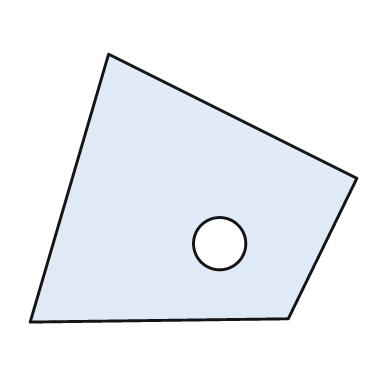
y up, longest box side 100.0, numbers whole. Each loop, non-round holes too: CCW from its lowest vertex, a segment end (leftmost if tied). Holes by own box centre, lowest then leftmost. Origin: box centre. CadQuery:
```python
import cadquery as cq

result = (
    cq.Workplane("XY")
    .moveTo(-50.0, -41.0)
    .lineTo(29.0, -40.0)
    .lineTo(50.0, 3.0)
    .lineTo(-26.0, 41.0)
    .close()
    .moveTo(8.0, -17.0)
    .circle(8.0)
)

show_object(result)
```